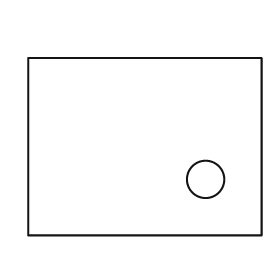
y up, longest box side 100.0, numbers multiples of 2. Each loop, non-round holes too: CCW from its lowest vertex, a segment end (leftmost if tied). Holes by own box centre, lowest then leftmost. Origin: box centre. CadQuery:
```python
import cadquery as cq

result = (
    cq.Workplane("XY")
    .moveTo(-50.0, -38.0)
    .lineTo(50.0, -38.0)
    .lineTo(50.0, 38.0)
    .lineTo(-50.0, 38.0)
    .close()
    .moveTo(26.0, -14.0)
    .circle(8.0)
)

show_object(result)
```